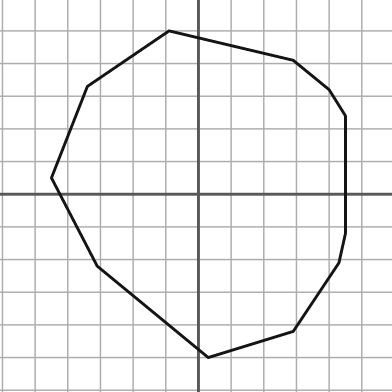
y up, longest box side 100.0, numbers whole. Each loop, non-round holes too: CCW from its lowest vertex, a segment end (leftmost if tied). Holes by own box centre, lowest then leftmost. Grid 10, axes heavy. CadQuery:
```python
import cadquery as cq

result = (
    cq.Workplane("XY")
    .moveTo(3.0, -50.0)
    .lineTo(29.0, -42.0)
    .lineTo(43.0, -21.0)
    .lineTo(45.0, -12.0)
    .lineTo(45.0, 24.0)
    .lineTo(40.0, 32.0)
    .lineTo(29.0, 41.0)
    .lineTo(-9.0, 50.0)
    .lineTo(-34.0, 33.0)
    .lineTo(-45.0, 5.0)
    .lineTo(-31.0, -22.0)
    .close()
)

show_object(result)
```